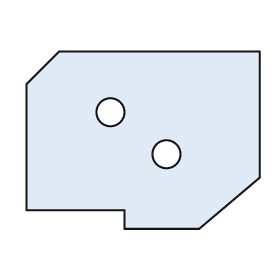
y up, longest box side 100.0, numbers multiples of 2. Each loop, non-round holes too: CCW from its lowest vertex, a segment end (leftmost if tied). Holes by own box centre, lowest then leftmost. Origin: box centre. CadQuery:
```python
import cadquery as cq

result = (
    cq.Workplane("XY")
    .moveTo(-8.0, -38.0)
    .lineTo(24.0, -38.0)
    .lineTo(50.0, -16.0)
    .lineTo(50.0, 38.0)
    .lineTo(-36.0, 38.0)
    .lineTo(-50.0, 24.0)
    .lineTo(-50.0, -30.0)
    .lineTo(-8.0, -30.0)
    .close()
    .moveTo(10.0, -6.0)
    .circle(6.0)
    .moveTo(-14.0, 12.0)
    .circle(6.0)
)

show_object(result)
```